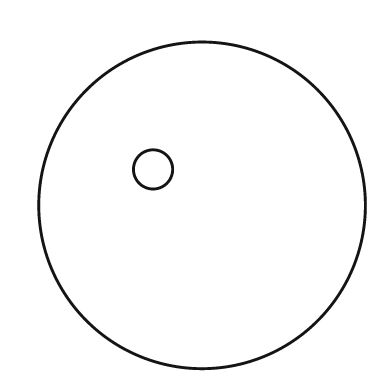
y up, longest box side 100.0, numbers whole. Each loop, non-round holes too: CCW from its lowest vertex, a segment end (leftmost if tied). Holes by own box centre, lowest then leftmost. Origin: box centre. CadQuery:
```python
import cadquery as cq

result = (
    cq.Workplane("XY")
    .moveTo(0.0, 0.0)
    .circle(50.0)
    .moveTo(-15.0, 11.0)
    .circle(6.0)
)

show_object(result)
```